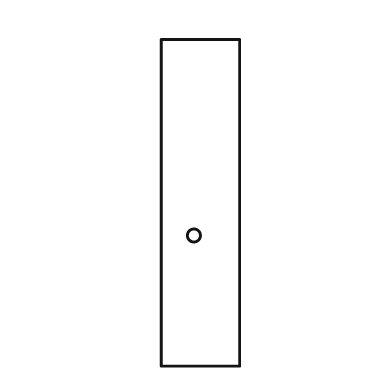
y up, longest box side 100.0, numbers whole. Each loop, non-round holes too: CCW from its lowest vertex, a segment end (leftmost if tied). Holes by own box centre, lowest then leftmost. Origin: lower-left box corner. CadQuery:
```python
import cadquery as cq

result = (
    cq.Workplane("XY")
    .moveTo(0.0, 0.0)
    .lineTo(24.0, 0.0)
    .lineTo(24.0, 100.0)
    .lineTo(0.0, 100.0)
    .close()
    .moveTo(10.0, 40.0)
    .circle(2.0)
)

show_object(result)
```